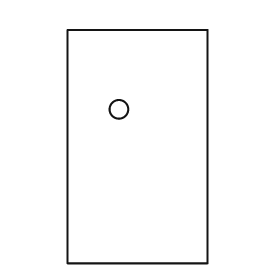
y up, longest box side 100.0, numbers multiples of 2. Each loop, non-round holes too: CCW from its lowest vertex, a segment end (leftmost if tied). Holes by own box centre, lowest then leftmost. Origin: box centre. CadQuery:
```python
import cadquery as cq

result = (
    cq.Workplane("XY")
    .moveTo(-30.0, -50.0)
    .lineTo(30.0, -50.0)
    .lineTo(30.0, 50.0)
    .lineTo(-30.0, 50.0)
    .close()
    .moveTo(-8.0, 16.0)
    .circle(4.0)
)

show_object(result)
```